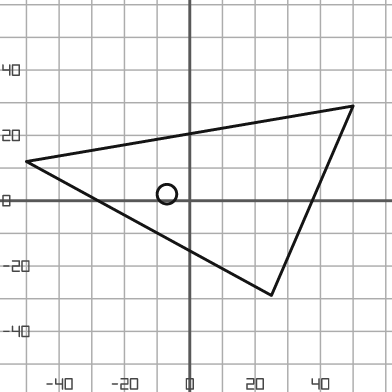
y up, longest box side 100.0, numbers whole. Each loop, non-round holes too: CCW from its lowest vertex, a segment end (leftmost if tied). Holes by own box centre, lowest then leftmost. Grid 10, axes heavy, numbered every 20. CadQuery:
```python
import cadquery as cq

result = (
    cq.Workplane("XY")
    .moveTo(25.0, -29.0)
    .lineTo(50.0, 29.0)
    .lineTo(-50.0, 12.0)
    .close()
    .moveTo(-7.0, 2.0)
    .circle(3.0)
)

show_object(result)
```